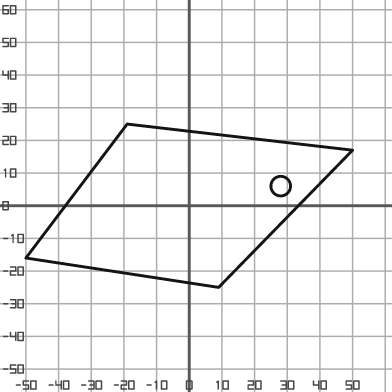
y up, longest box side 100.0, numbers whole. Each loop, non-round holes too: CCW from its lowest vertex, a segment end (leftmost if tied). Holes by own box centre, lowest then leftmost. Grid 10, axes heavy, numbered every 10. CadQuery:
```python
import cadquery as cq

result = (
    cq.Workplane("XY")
    .moveTo(9.0, -25.0)
    .lineTo(50.0, 17.0)
    .lineTo(-19.0, 25.0)
    .lineTo(-50.0, -16.0)
    .close()
    .moveTo(28.0, 6.0)
    .circle(3.0)
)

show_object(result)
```